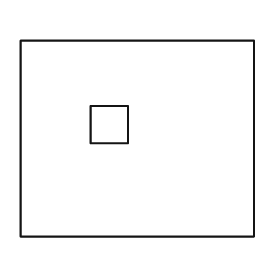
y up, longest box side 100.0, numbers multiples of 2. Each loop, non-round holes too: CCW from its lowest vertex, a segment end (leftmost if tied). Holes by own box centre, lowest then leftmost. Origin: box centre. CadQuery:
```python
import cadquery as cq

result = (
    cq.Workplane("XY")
    .moveTo(-50.0, -42.0)
    .lineTo(50.0, -42.0)
    .lineTo(50.0, 42.0)
    .lineTo(-50.0, 42.0)
    .close()
    .moveTo(-20.0, -2.0)
    .lineTo(-4.0, -2.0)
    .lineTo(-4.0, 14.0)
    .lineTo(-20.0, 14.0)
    .close()
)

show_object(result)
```